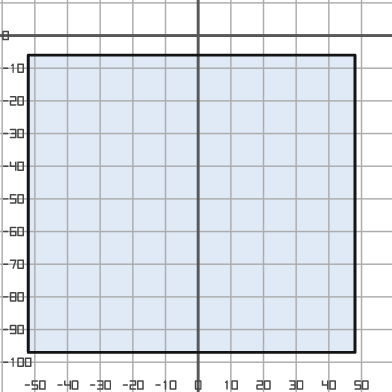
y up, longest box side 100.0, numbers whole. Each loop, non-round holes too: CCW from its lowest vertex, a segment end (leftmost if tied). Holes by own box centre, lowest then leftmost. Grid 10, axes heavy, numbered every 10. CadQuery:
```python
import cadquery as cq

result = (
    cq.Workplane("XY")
    .moveTo(-52.0, -97.0)
    .lineTo(48.0, -97.0)
    .lineTo(48.0, -6.0)
    .lineTo(-52.0, -6.0)
    .close()
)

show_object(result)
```